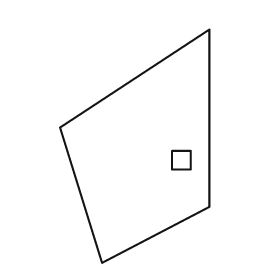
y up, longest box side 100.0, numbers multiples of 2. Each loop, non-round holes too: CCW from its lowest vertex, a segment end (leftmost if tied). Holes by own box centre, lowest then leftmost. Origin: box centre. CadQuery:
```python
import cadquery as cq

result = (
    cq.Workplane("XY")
    .moveTo(-14.0, -50.0)
    .lineTo(32.0, -26.0)
    .lineTo(32.0, 50.0)
    .lineTo(-32.0, 8.0)
    .close()
    .moveTo(16.0, -10.0)
    .lineTo(24.0, -10.0)
    .lineTo(24.0, -2.0)
    .lineTo(16.0, -2.0)
    .close()
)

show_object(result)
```